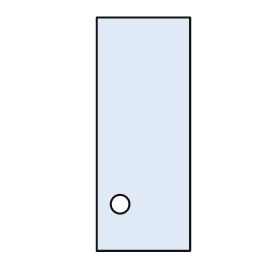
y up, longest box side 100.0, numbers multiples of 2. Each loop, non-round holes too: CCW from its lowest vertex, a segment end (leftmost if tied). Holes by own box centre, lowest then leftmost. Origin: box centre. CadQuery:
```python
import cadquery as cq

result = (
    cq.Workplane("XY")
    .moveTo(-20.0, -50.0)
    .lineTo(20.0, -50.0)
    .lineTo(20.0, 50.0)
    .lineTo(-20.0, 50.0)
    .close()
    .moveTo(-10.0, -30.0)
    .circle(4.0)
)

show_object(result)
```